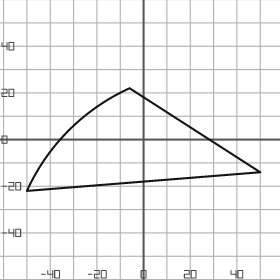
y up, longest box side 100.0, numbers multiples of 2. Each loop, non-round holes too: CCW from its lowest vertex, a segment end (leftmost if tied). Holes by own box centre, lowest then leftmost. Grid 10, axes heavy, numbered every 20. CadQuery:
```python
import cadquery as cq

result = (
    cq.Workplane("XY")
    .moveTo(-50.0, -22.0)
    .lineTo(50.0, -14.0)
    .lineTo(-6.0, 22.0)
    .threePointArc((-32.0, 4.0), (-50.0, -22.0))
    .close()
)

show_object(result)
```